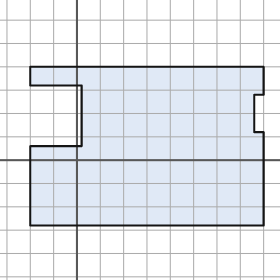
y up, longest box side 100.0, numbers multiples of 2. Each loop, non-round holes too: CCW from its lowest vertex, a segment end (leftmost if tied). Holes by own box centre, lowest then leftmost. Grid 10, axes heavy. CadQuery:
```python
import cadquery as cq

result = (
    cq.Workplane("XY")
    .moveTo(-20.0, -28.0)
    .lineTo(80.0, -28.0)
    .lineTo(80.0, 12.0)
    .lineTo(76.0, 12.0)
    .lineTo(76.0, 28.0)
    .lineTo(80.0, 28.0)
    .lineTo(80.0, 40.0)
    .lineTo(-20.0, 40.0)
    .lineTo(-20.0, 32.0)
    .lineTo(2.0, 32.0)
    .lineTo(2.0, 6.0)
    .lineTo(-20.0, 6.0)
    .close()
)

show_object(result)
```